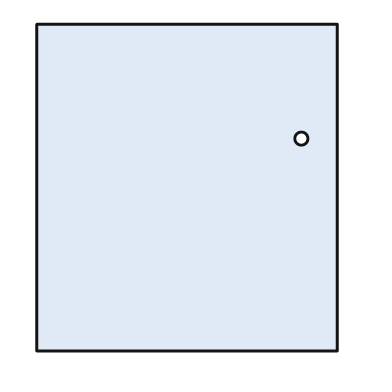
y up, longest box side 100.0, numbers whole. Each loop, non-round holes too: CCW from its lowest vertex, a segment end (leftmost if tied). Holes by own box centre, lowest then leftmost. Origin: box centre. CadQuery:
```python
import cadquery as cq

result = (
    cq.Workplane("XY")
    .moveTo(-46.0, -50.0)
    .lineTo(46.0, -50.0)
    .lineTo(46.0, 50.0)
    .lineTo(-46.0, 50.0)
    .close()
    .moveTo(35.0, 15.0)
    .circle(2.0)
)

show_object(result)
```